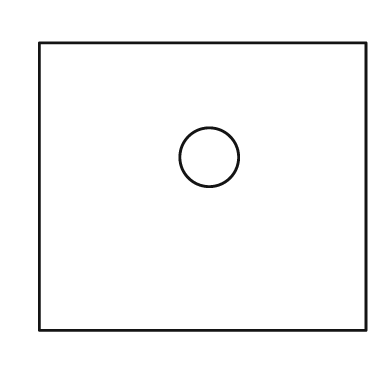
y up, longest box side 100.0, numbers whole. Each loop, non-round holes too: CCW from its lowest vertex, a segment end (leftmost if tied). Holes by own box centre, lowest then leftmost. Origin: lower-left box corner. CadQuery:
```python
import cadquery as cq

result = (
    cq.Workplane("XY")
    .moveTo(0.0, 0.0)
    .lineTo(100.0, 0.0)
    .lineTo(100.0, 88.0)
    .lineTo(0.0, 88.0)
    .close()
    .moveTo(52.0, 53.0)
    .circle(9.0)
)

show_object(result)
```